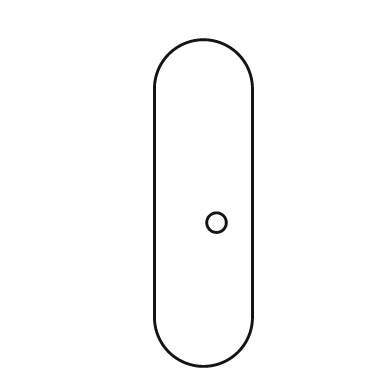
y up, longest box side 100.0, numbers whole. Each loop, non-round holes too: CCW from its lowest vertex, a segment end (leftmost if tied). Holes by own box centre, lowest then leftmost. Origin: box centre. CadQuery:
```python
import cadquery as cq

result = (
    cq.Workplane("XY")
    .moveTo(-15.0, -35.0)
    .threePointArc((0.0, -50.0), (15.0, -35.0))
    .lineTo(15.0, 35.0)
    .threePointArc((0.0, 50.0), (-15.0, 35.0))
    .close()
    .moveTo(4.0, -6.0)
    .circle(3.0)
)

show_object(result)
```